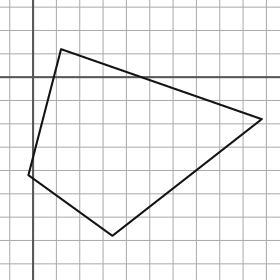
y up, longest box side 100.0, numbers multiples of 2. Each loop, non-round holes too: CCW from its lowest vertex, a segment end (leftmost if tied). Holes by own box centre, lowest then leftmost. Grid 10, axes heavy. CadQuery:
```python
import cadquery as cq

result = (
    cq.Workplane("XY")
    .moveTo(34.0, -68.0)
    .lineTo(98.0, -18.0)
    .lineTo(12.0, 12.0)
    .lineTo(-2.0, -42.0)
    .close()
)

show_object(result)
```